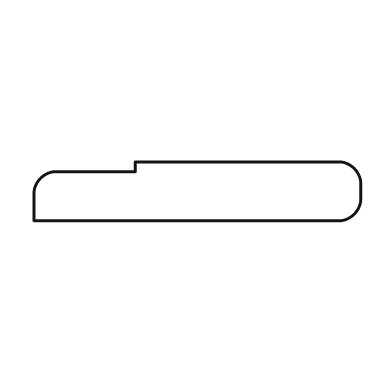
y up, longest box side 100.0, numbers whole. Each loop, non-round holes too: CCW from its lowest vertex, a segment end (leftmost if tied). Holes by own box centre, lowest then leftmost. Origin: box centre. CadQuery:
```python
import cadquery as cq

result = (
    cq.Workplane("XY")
    .moveTo(-50.0, -9.0)
    .lineTo(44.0, -9.0)
    .threePointArc((48.0, -7.0), (50.0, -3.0))
    .lineTo(50.0, 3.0)
    .threePointArc((48.0, 7.0), (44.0, 9.0))
    .lineTo(-19.0, 9.0)
    .lineTo(-19.0, 6.0)
    .lineTo(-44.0, 6.0)
    .threePointArc((-48.0, 4.0), (-50.0, 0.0))
    .close()
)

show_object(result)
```